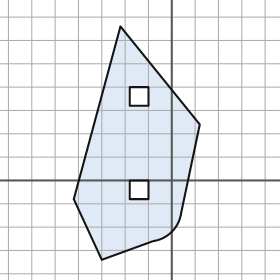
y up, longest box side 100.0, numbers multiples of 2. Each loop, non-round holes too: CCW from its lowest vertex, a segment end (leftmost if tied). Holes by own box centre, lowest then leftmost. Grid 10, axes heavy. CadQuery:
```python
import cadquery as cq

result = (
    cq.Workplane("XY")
    .moveTo(-30.0, -34.0)
    .lineTo(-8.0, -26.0)
    .threePointArc((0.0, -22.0), (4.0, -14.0))
    .lineTo(12.0, 24.0)
    .lineTo(-22.0, 66.0)
    .lineTo(-42.0, -8.0)
    .close()
    .moveTo(-18.0, -8.0)
    .lineTo(-10.0, -8.0)
    .lineTo(-10.0, 0.0)
    .lineTo(-18.0, 0.0)
    .close()
    .moveTo(-18.0, 32.0)
    .lineTo(-10.0, 32.0)
    .lineTo(-10.0, 40.0)
    .lineTo(-18.0, 40.0)
    .close()
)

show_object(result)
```